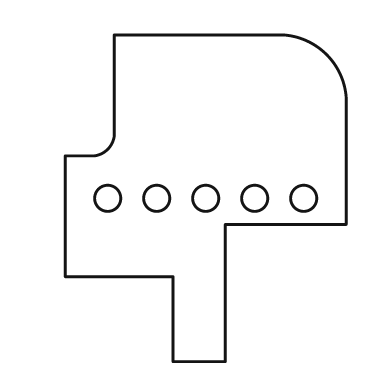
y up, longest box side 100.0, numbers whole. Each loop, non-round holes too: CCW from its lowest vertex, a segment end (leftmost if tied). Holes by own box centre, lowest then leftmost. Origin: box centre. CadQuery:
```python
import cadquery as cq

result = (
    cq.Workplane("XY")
    .moveTo(-10.0, -50.0)
    .lineTo(6.0, -50.0)
    .lineTo(6.0, -8.0)
    .lineTo(43.0, -8.0)
    .lineTo(43.0, 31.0)
    .threePointArc((37.0, 44.0), (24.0, 50.0))
    .lineTo(-28.0, 50.0)
    .lineTo(-28.0, 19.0)
    .threePointArc((-30.0, 15.0), (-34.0, 13.0))
    .lineTo(-43.0, 13.0)
    .lineTo(-43.0, -24.0)
    .lineTo(-10.0, -24.0)
    .close()
    .moveTo(-30.0, 0.0)
    .circle(4.0)
    .moveTo(-15.0, 0.0)
    .circle(4.0)
    .moveTo(0.0, 0.0)
    .circle(4.0)
    .moveTo(15.0, 0.0)
    .circle(4.0)
    .moveTo(30.0, 0.0)
    .circle(4.0)
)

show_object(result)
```